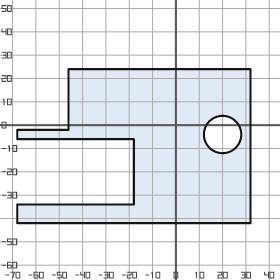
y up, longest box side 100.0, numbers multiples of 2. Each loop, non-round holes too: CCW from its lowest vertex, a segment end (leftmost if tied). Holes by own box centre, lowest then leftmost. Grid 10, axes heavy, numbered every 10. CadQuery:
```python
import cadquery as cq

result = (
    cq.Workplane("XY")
    .moveTo(-68.0, -42.0)
    .lineTo(32.0, -42.0)
    .lineTo(32.0, 24.0)
    .lineTo(-46.0, 24.0)
    .lineTo(-46.0, -2.0)
    .lineTo(-68.0, -2.0)
    .lineTo(-68.0, -6.0)
    .lineTo(-18.0, -6.0)
    .lineTo(-18.0, -34.0)
    .lineTo(-68.0, -34.0)
    .close()
    .moveTo(20.0, -4.0)
    .circle(8.0)
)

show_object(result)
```